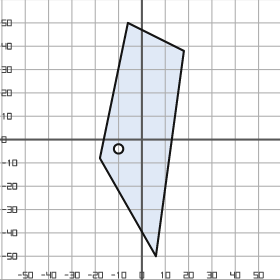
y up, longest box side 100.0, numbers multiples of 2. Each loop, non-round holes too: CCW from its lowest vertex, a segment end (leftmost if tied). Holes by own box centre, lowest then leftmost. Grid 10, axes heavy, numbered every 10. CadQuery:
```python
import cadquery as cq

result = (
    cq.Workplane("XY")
    .moveTo(6.0, -50.0)
    .lineTo(18.0, 38.0)
    .lineTo(-6.0, 50.0)
    .lineTo(-18.0, -8.0)
    .close()
    .moveTo(-10.0, -4.0)
    .circle(2.0)
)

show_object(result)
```